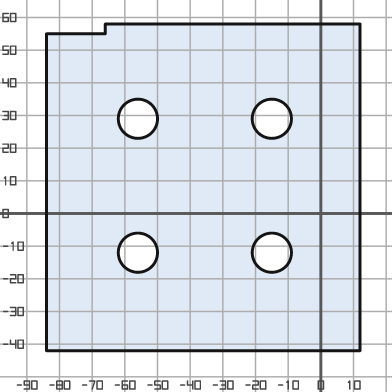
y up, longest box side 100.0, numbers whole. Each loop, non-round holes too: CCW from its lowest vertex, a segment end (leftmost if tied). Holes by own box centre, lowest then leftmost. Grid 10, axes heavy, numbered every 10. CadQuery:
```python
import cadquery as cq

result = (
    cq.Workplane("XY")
    .moveTo(-84.0, -42.0)
    .lineTo(12.0, -42.0)
    .lineTo(12.0, 58.0)
    .lineTo(-66.0, 58.0)
    .lineTo(-66.0, 55.0)
    .lineTo(-84.0, 55.0)
    .close()
    .moveTo(-56.0, -12.0)
    .circle(6.0)
    .moveTo(-15.0, -12.0)
    .circle(6.0)
    .moveTo(-56.0, 29.0)
    .circle(6.0)
    .moveTo(-15.0, 29.0)
    .circle(6.0)
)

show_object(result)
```